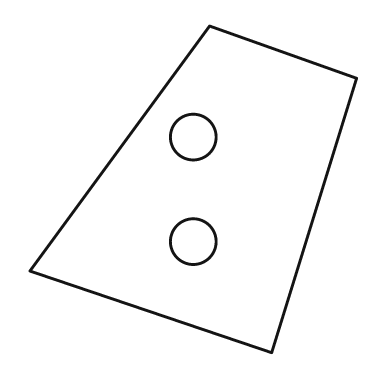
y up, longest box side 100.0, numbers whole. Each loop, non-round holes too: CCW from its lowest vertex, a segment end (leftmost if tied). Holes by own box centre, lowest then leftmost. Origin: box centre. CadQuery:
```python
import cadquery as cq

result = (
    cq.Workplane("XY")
    .moveTo(24.0, -50.0)
    .lineTo(50.0, 34.0)
    .lineTo(5.0, 50.0)
    .lineTo(-50.0, -25.0)
    .close()
    .moveTo(0.0, -16.0)
    .circle(7.0)
    .moveTo(0.0, 16.0)
    .circle(7.0)
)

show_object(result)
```